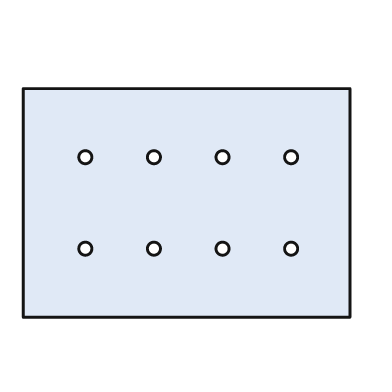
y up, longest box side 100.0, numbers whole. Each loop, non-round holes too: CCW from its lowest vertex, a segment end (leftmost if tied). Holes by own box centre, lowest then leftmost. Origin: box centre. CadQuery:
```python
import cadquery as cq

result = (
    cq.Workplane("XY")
    .moveTo(-50.0, -35.0)
    .lineTo(50.0, -35.0)
    .lineTo(50.0, 35.0)
    .lineTo(-50.0, 35.0)
    .close()
    .moveTo(-31.0, -14.0)
    .circle(2.0)
    .moveTo(-10.0, -14.0)
    .circle(2.0)
    .moveTo(11.0, -14.0)
    .circle(2.0)
    .moveTo(32.0, -14.0)
    .circle(2.0)
    .moveTo(-31.0, 14.0)
    .circle(2.0)
    .moveTo(-10.0, 14.0)
    .circle(2.0)
    .moveTo(11.0, 14.0)
    .circle(2.0)
    .moveTo(32.0, 14.0)
    .circle(2.0)
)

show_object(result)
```